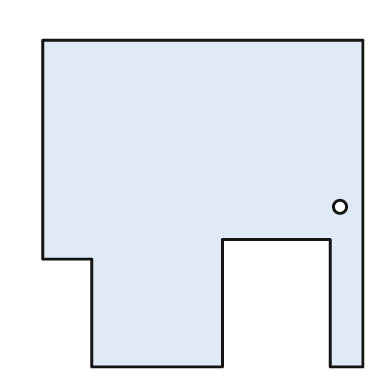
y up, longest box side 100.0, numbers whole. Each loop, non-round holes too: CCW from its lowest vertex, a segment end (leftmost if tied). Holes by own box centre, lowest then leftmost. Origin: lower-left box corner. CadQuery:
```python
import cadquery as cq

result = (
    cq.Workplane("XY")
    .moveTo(15.0, 0.0)
    .lineTo(55.0, 0.0)
    .lineTo(55.0, 39.0)
    .lineTo(88.0, 39.0)
    .lineTo(88.0, 0.0)
    .lineTo(98.0, 0.0)
    .lineTo(98.0, 100.0)
    .lineTo(0.0, 100.0)
    .lineTo(0.0, 33.0)
    .lineTo(15.0, 33.0)
    .close()
    .moveTo(91.0, 49.0)
    .circle(2.0)
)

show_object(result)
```